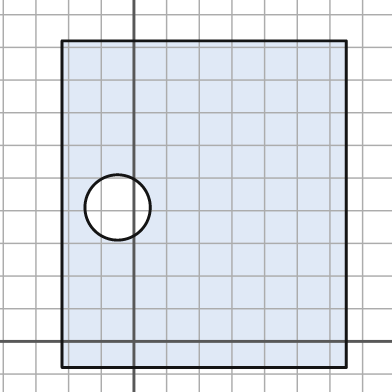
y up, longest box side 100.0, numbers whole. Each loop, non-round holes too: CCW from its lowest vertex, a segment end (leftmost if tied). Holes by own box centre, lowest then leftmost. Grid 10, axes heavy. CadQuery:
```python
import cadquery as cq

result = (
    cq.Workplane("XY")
    .moveTo(-22.0, -8.0)
    .lineTo(65.0, -8.0)
    .lineTo(65.0, 92.0)
    .lineTo(-22.0, 92.0)
    .close()
    .moveTo(-5.0, 41.0)
    .circle(10.0)
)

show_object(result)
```